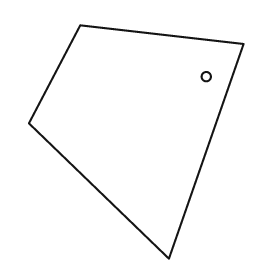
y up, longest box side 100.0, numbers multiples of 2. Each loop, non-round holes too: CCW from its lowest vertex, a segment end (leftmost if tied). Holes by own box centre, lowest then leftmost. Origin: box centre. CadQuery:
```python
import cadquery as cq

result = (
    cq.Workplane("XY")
    .moveTo(14.0, -50.0)
    .lineTo(46.0, 42.0)
    .lineTo(-24.0, 50.0)
    .lineTo(-46.0, 8.0)
    .close()
    .moveTo(30.0, 28.0)
    .circle(2.0)
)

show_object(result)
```